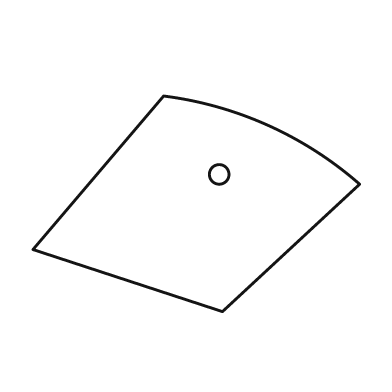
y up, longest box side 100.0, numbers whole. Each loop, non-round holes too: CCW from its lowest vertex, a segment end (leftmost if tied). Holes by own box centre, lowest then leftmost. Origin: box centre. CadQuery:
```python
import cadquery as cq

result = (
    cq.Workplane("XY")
    .moveTo(8.0, -33.0)
    .lineTo(50.0, 6.0)
    .threePointArc((22.0, 24.0), (-10.0, 33.0))
    .lineTo(-50.0, -14.0)
    .close()
    .moveTo(7.0, 9.0)
    .circle(3.0)
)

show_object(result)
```